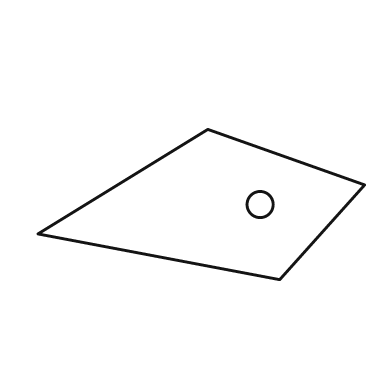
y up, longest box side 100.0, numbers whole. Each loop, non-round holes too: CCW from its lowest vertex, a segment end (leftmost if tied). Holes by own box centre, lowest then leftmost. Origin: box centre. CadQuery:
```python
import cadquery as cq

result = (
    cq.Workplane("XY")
    .moveTo(24.0, -23.0)
    .lineTo(50.0, 6.0)
    .lineTo(2.0, 23.0)
    .lineTo(-50.0, -9.0)
    .close()
    .moveTo(18.0, 0.0)
    .circle(4.0)
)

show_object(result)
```